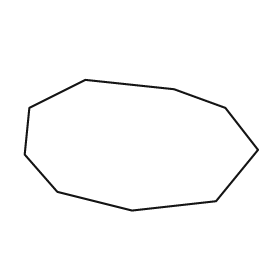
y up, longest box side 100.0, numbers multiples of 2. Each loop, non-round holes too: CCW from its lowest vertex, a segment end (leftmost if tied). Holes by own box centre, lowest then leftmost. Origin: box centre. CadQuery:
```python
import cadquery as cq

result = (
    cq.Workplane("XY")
    .moveTo(-4.0, -28.0)
    .lineTo(32.0, -24.0)
    .lineTo(50.0, -2.0)
    .lineTo(36.0, 16.0)
    .lineTo(14.0, 24.0)
    .lineTo(-24.0, 28.0)
    .lineTo(-48.0, 16.0)
    .lineTo(-50.0, -4.0)
    .lineTo(-36.0, -20.0)
    .close()
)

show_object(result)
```